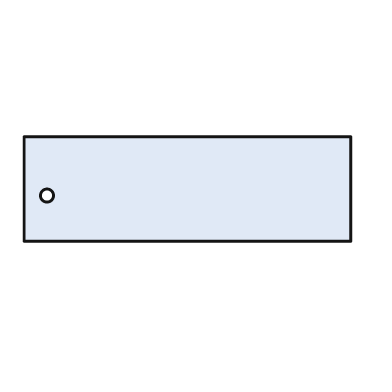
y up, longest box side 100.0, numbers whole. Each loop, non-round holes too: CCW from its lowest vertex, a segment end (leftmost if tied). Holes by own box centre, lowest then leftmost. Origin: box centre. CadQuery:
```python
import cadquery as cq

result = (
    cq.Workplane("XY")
    .moveTo(-50.0, -16.0)
    .lineTo(50.0, -16.0)
    .lineTo(50.0, 16.0)
    .lineTo(-50.0, 16.0)
    .close()
    .moveTo(-43.0, -2.0)
    .circle(2.0)
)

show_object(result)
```